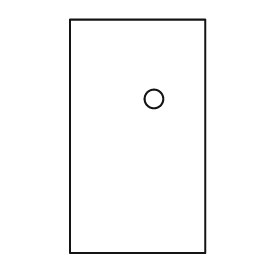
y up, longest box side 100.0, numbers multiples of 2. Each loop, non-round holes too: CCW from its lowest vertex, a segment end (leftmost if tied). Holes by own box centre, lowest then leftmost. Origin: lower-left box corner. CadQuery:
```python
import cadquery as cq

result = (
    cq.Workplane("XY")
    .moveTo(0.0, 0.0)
    .lineTo(58.0, 0.0)
    .lineTo(58.0, 100.0)
    .lineTo(0.0, 100.0)
    .close()
    .moveTo(36.0, 66.0)
    .circle(4.0)
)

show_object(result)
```